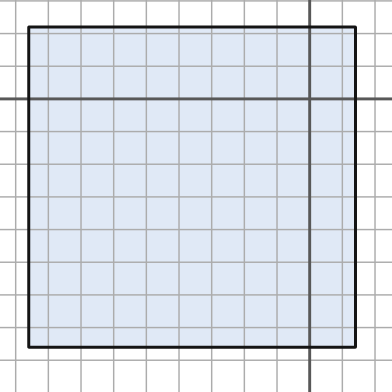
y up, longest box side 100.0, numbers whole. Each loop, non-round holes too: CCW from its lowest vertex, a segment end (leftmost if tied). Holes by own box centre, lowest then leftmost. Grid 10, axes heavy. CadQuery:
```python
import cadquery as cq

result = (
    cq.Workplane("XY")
    .moveTo(-86.0, -76.0)
    .lineTo(14.0, -76.0)
    .lineTo(14.0, 22.0)
    .lineTo(-86.0, 22.0)
    .close()
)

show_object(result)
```